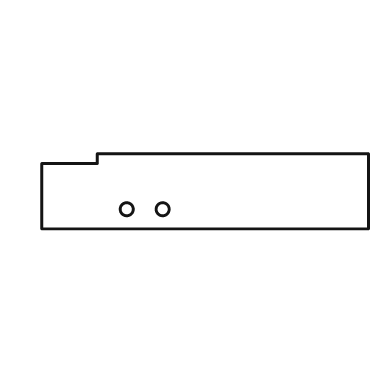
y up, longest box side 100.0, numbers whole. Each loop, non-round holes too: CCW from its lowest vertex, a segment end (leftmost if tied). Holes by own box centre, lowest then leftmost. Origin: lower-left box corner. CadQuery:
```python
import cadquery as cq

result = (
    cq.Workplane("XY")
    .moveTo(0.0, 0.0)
    .lineTo(100.0, 0.0)
    .lineTo(100.0, 23.0)
    .lineTo(17.0, 23.0)
    .lineTo(17.0, 20.0)
    .lineTo(0.0, 20.0)
    .close()
    .moveTo(26.0, 6.0)
    .circle(2.0)
    .moveTo(37.0, 6.0)
    .circle(2.0)
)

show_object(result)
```